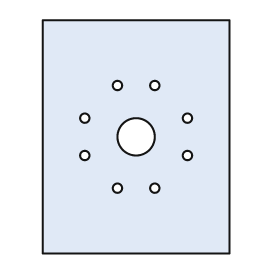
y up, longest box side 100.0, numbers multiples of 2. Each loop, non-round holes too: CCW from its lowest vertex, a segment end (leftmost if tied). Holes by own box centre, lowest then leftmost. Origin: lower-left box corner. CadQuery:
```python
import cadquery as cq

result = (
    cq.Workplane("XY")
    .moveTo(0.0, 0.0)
    .lineTo(80.0, 0.0)
    .lineTo(80.0, 100.0)
    .lineTo(0.0, 100.0)
    .close()
    .moveTo(32.0, 28.0)
    .circle(2.0)
    .moveTo(48.0, 28.0)
    .circle(2.0)
    .moveTo(18.0, 42.0)
    .circle(2.0)
    .moveTo(62.0, 42.0)
    .circle(2.0)
    .moveTo(40.0, 50.0)
    .circle(8.0)
    .moveTo(18.0, 58.0)
    .circle(2.0)
    .moveTo(62.0, 58.0)
    .circle(2.0)
    .moveTo(32.0, 72.0)
    .circle(2.0)
    .moveTo(48.0, 72.0)
    .circle(2.0)
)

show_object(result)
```